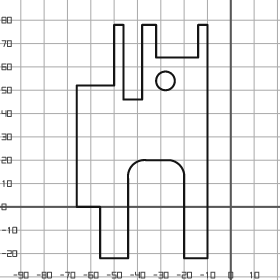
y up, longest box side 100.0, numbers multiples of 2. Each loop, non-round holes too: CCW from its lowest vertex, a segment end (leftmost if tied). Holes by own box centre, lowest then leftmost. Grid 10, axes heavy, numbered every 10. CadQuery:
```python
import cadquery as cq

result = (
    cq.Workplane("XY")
    .moveTo(-56.0, -22.0)
    .lineTo(-44.0, -22.0)
    .lineTo(-44.0, 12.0)
    .threePointArc((-42.0, 18.0), (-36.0, 20.0))
    .lineTo(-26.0, 20.0)
    .threePointArc((-22.0, 18.0), (-20.0, 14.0))
    .lineTo(-20.0, -22.0)
    .lineTo(-10.0, -22.0)
    .lineTo(-10.0, 78.0)
    .lineTo(-14.0, 78.0)
    .lineTo(-14.0, 64.0)
    .lineTo(-32.0, 64.0)
    .lineTo(-32.0, 78.0)
    .lineTo(-38.0, 78.0)
    .lineTo(-38.0, 46.0)
    .lineTo(-46.0, 46.0)
    .lineTo(-46.0, 78.0)
    .lineTo(-50.0, 78.0)
    .lineTo(-50.0, 52.0)
    .lineTo(-66.0, 52.0)
    .lineTo(-66.0, 0.0)
    .lineTo(-56.0, 0.0)
    .close()
    .moveTo(-28.0, 54.0)
    .circle(4.0)
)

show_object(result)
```